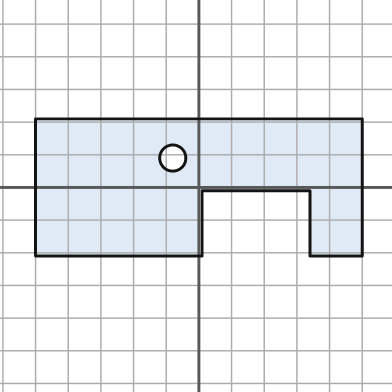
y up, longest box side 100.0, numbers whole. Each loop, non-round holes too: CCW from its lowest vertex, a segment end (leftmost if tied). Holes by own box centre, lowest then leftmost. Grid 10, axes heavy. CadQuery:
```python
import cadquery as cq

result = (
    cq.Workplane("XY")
    .moveTo(-50.0, -21.0)
    .lineTo(1.0, -21.0)
    .lineTo(1.0, -1.0)
    .lineTo(34.0, -1.0)
    .lineTo(34.0, -21.0)
    .lineTo(50.0, -21.0)
    .lineTo(50.0, 21.0)
    .lineTo(-50.0, 21.0)
    .close()
    .moveTo(-8.0, 9.0)
    .circle(4.0)
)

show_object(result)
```